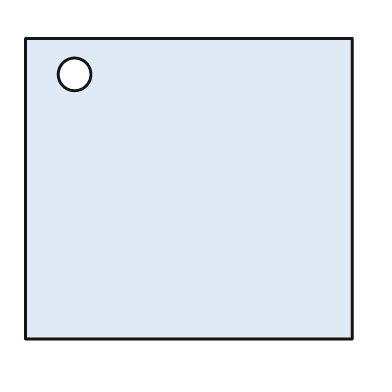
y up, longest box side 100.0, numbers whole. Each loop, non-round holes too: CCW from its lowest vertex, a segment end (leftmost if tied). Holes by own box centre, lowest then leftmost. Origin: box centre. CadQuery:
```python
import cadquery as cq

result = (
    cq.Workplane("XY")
    .moveTo(-50.0, -46.0)
    .lineTo(50.0, -46.0)
    .lineTo(50.0, 46.0)
    .lineTo(-50.0, 46.0)
    .close()
    .moveTo(-35.0, 35.0)
    .circle(5.0)
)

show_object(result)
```